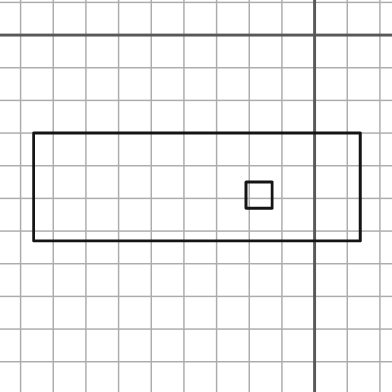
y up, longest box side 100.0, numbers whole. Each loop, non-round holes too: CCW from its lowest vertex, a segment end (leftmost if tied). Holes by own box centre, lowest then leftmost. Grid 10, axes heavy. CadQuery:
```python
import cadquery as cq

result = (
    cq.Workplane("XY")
    .moveTo(-86.0, -63.0)
    .lineTo(14.0, -63.0)
    .lineTo(14.0, -30.0)
    .lineTo(-86.0, -30.0)
    .close()
    .moveTo(-21.0, -53.0)
    .lineTo(-13.0, -53.0)
    .lineTo(-13.0, -45.0)
    .lineTo(-21.0, -45.0)
    .close()
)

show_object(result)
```